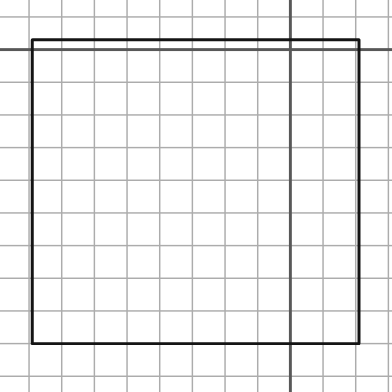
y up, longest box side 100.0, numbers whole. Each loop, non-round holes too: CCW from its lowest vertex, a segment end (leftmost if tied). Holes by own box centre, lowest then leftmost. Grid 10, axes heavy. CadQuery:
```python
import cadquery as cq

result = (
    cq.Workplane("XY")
    .moveTo(-79.0, -90.0)
    .lineTo(21.0, -90.0)
    .lineTo(21.0, 3.0)
    .lineTo(-79.0, 3.0)
    .close()
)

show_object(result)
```